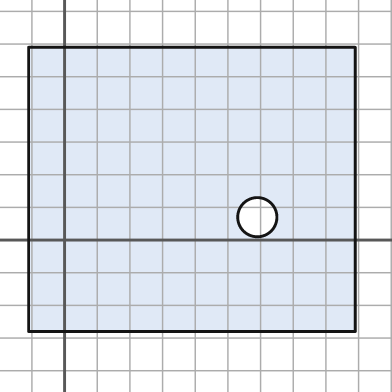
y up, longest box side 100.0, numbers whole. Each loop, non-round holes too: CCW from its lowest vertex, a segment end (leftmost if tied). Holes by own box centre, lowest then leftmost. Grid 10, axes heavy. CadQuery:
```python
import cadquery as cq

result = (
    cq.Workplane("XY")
    .moveTo(-11.0, -28.0)
    .lineTo(89.0, -28.0)
    .lineTo(89.0, 59.0)
    .lineTo(-11.0, 59.0)
    .close()
    .moveTo(59.0, 7.0)
    .circle(6.0)
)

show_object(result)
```